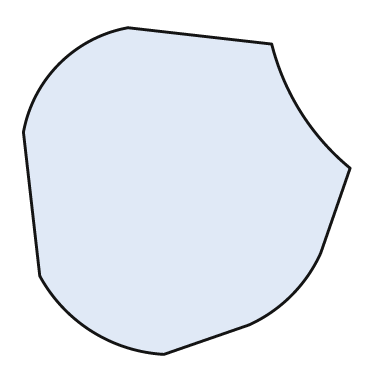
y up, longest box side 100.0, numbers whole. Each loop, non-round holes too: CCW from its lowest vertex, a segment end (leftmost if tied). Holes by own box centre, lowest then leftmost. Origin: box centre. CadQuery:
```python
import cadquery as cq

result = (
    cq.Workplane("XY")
    .moveTo(-7.0, -50.0)
    .lineTo(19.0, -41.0)
    .threePointArc((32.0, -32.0), (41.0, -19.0))
    .lineTo(50.0, 7.0)
    .threePointArc((35.0, 24.0), (26.0, 45.0))
    .lineTo(-18.0, 50.0)
    .threePointArc((-39.0, 39.0), (-50.0, 18.0))
    .lineTo(-45.0, -26.0)
    .threePointArc((-29.0, -43.0), (-7.0, -50.0))
    .close()
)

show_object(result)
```